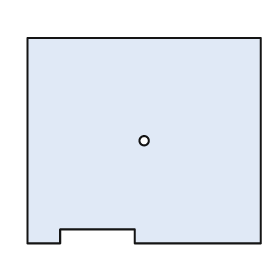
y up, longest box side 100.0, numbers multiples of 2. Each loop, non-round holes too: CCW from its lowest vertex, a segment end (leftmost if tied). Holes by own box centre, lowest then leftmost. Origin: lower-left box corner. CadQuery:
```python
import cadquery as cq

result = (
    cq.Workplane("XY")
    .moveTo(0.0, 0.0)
    .lineTo(14.0, 0.0)
    .lineTo(14.0, 6.0)
    .lineTo(46.0, 6.0)
    .lineTo(46.0, 0.0)
    .lineTo(100.0, 0.0)
    .lineTo(100.0, 88.0)
    .lineTo(0.0, 88.0)
    .close()
    .moveTo(50.0, 44.0)
    .circle(2.0)
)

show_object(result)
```